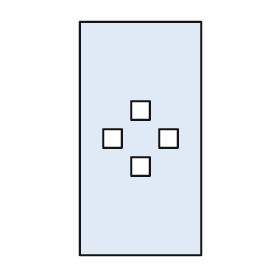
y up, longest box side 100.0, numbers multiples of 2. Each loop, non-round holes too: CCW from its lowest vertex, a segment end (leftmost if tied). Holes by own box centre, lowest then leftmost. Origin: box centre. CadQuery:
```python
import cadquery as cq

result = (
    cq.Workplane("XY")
    .moveTo(-26.0, -50.0)
    .lineTo(26.0, -50.0)
    .lineTo(26.0, 50.0)
    .lineTo(-26.0, 50.0)
    .close()
    .moveTo(-4.0, -16.0)
    .lineTo(4.0, -16.0)
    .lineTo(4.0, -8.0)
    .lineTo(-4.0, -8.0)
    .close()
    .moveTo(-16.0, -4.0)
    .lineTo(-8.0, -4.0)
    .lineTo(-8.0, 4.0)
    .lineTo(-16.0, 4.0)
    .close()
    .moveTo(8.0, -4.0)
    .lineTo(16.0, -4.0)
    .lineTo(16.0, 4.0)
    .lineTo(8.0, 4.0)
    .close()
    .moveTo(-4.0, 8.0)
    .lineTo(4.0, 8.0)
    .lineTo(4.0, 16.0)
    .lineTo(-4.0, 16.0)
    .close()
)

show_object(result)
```